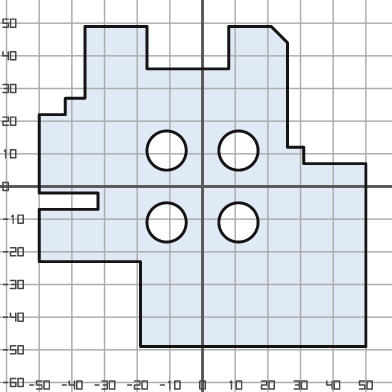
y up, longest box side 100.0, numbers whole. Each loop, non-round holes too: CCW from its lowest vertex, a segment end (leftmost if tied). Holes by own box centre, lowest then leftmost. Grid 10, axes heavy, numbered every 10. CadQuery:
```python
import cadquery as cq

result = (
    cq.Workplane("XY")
    .moveTo(-19.0, -49.0)
    .lineTo(50.0, -49.0)
    .lineTo(50.0, 7.0)
    .lineTo(31.0, 7.0)
    .lineTo(31.0, 12.0)
    .lineTo(26.0, 12.0)
    .lineTo(26.0, 44.0)
    .lineTo(21.0, 49.0)
    .lineTo(8.0, 49.0)
    .lineTo(8.0, 36.0)
    .lineTo(-17.0, 36.0)
    .lineTo(-17.0, 49.0)
    .lineTo(-36.0, 49.0)
    .lineTo(-36.0, 27.0)
    .lineTo(-42.0, 27.0)
    .lineTo(-42.0, 22.0)
    .lineTo(-50.0, 22.0)
    .lineTo(-50.0, -2.0)
    .lineTo(-32.0, -2.0)
    .lineTo(-32.0, -7.0)
    .lineTo(-50.0, -7.0)
    .lineTo(-50.0, -23.0)
    .lineTo(-19.0, -23.0)
    .close()
    .moveTo(-11.0, -11.0)
    .circle(6.0)
    .moveTo(11.0, -11.0)
    .circle(6.0)
    .moveTo(-11.0, 11.0)
    .circle(6.0)
    .moveTo(11.0, 11.0)
    .circle(6.0)
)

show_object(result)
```